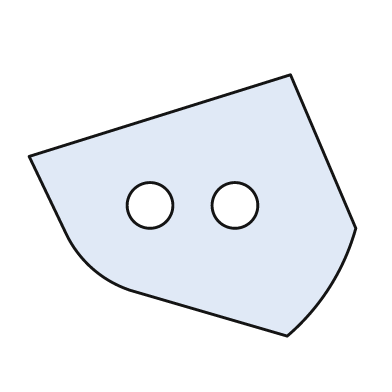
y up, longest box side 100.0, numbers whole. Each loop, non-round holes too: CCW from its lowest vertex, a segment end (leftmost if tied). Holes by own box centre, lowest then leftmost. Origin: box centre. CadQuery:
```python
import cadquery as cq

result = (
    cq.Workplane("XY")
    .moveTo(29.0, -40.0)
    .threePointArc((42.0, -25.0), (50.0, -7.0))
    .lineTo(30.0, 40.0)
    .lineTo(-50.0, 15.0)
    .lineTo(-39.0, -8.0)
    .threePointArc((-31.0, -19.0), (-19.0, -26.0))
    .close()
    .moveTo(-13.0, 0.0)
    .circle(7.0)
    .moveTo(13.0, 0.0)
    .circle(7.0)
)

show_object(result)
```